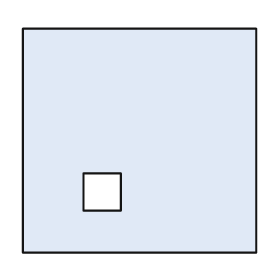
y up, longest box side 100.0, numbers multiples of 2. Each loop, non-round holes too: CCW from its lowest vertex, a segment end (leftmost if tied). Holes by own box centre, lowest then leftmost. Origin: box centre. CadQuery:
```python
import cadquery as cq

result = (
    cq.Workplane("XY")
    .moveTo(-50.0, -48.0)
    .lineTo(50.0, -48.0)
    .lineTo(50.0, 48.0)
    .lineTo(-50.0, 48.0)
    .close()
    .moveTo(-24.0, -30.0)
    .lineTo(-8.0, -30.0)
    .lineTo(-8.0, -14.0)
    .lineTo(-24.0, -14.0)
    .close()
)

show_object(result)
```